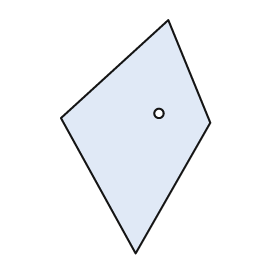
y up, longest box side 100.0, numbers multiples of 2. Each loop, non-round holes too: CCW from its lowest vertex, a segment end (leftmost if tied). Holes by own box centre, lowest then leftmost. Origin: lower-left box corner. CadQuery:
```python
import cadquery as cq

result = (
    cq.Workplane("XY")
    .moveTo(32.0, 0.0)
    .lineTo(64.0, 56.0)
    .lineTo(46.0, 100.0)
    .lineTo(0.0, 58.0)
    .close()
    .moveTo(42.0, 60.0)
    .circle(2.0)
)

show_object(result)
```